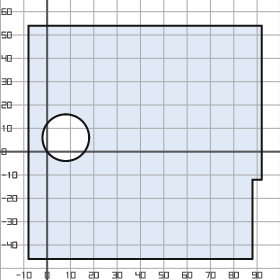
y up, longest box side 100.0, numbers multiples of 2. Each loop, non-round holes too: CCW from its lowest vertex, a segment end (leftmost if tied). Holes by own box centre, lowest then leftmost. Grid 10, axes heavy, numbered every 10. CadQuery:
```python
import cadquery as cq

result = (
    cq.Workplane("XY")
    .moveTo(-8.0, -46.0)
    .lineTo(88.0, -46.0)
    .lineTo(88.0, -12.0)
    .lineTo(92.0, -12.0)
    .lineTo(92.0, 54.0)
    .lineTo(-8.0, 54.0)
    .close()
    .moveTo(8.0, 6.0)
    .circle(10.0)
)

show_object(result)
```